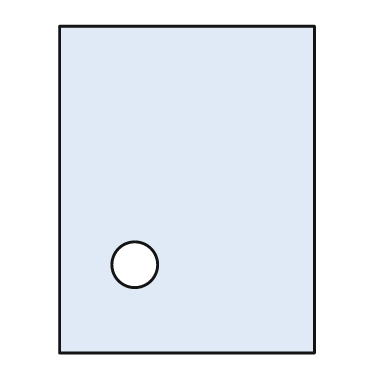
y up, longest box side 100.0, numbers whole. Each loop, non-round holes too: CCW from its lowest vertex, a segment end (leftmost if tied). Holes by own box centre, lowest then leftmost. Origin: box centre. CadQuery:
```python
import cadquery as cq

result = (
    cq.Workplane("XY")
    .moveTo(-39.0, -50.0)
    .lineTo(39.0, -50.0)
    .lineTo(39.0, 50.0)
    .lineTo(-39.0, 50.0)
    .close()
    .moveTo(-16.0, -23.0)
    .circle(7.0)
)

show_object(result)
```